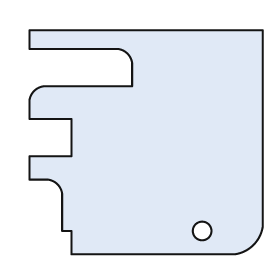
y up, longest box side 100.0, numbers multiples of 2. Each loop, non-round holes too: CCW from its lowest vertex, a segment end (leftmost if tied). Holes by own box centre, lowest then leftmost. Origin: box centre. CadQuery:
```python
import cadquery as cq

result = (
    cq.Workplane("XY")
    .moveTo(-32.0, -48.0)
    .lineTo(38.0, -48.0)
    .threePointArc((46.0, -44.0), (50.0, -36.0))
    .lineTo(50.0, 48.0)
    .lineTo(-50.0, 48.0)
    .lineTo(-50.0, 40.0)
    .lineTo(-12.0, 40.0)
    .threePointArc((-8.0, 38.0), (-6.0, 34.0))
    .lineTo(-6.0, 24.0)
    .lineTo(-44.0, 24.0)
    .threePointArc((-48.0, 22.0), (-50.0, 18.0))
    .lineTo(-50.0, 10.0)
    .lineTo(-32.0, 10.0)
    .lineTo(-32.0, -6.0)
    .lineTo(-50.0, -6.0)
    .lineTo(-50.0, -16.0)
    .lineTo(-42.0, -16.0)
    .threePointArc((-38.0, -18.0), (-36.0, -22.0))
    .lineTo(-36.0, -38.0)
    .lineTo(-32.0, -38.0)
    .close()
    .moveTo(24.0, -38.0)
    .circle(4.0)
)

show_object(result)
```